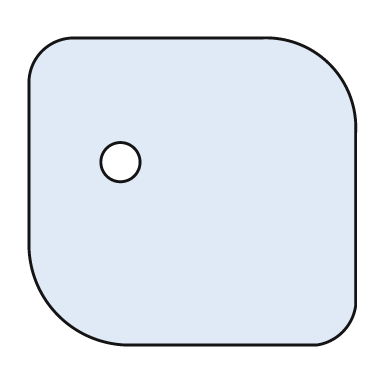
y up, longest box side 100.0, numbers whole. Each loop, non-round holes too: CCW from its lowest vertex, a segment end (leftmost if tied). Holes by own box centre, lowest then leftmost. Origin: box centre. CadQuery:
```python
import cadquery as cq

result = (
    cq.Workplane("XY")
    .moveTo(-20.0, -47.0)
    .lineTo(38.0, -47.0)
    .threePointArc((46.0, -43.0), (50.0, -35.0))
    .lineTo(50.0, 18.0)
    .threePointArc((42.0, 39.0), (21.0, 47.0))
    .lineTo(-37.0, 47.0)
    .threePointArc((-46.0, 43.0), (-50.0, 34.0))
    .lineTo(-50.0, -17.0)
    .threePointArc((-41.0, -38.0), (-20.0, -47.0))
    .close()
    .moveTo(-22.0, 9.0)
    .circle(6.0)
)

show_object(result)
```